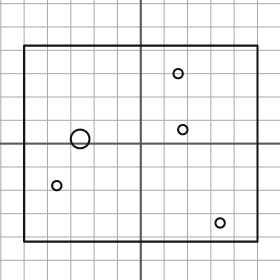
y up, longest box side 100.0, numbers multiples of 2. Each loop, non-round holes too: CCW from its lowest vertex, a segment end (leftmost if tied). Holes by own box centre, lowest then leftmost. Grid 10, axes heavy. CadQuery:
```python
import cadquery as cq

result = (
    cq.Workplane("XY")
    .moveTo(-50.0, -42.0)
    .lineTo(50.0, -42.0)
    .lineTo(50.0, 42.0)
    .lineTo(-50.0, 42.0)
    .close()
    .moveTo(34.0, -34.0)
    .circle(2.0)
    .moveTo(-36.0, -18.0)
    .circle(2.0)
    .moveTo(-26.0, 2.0)
    .circle(4.0)
    .moveTo(18.0, 6.0)
    .circle(2.0)
    .moveTo(16.0, 30.0)
    .circle(2.0)
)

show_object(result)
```